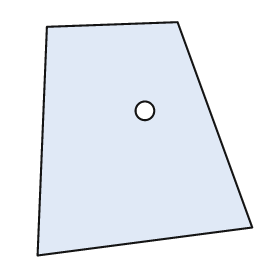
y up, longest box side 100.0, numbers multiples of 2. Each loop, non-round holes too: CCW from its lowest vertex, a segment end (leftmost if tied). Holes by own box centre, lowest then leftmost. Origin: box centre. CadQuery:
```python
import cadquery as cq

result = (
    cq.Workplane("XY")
    .moveTo(-46.0, -50.0)
    .lineTo(46.0, -38.0)
    .lineTo(14.0, 50.0)
    .lineTo(-42.0, 48.0)
    .close()
    .moveTo(0.0, 12.0)
    .circle(4.0)
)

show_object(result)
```